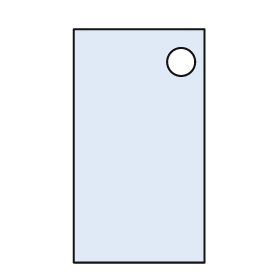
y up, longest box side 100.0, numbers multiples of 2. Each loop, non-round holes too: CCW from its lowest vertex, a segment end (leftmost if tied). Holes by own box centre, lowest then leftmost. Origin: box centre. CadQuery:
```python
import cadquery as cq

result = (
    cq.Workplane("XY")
    .moveTo(-28.0, -50.0)
    .lineTo(28.0, -50.0)
    .lineTo(28.0, 50.0)
    .lineTo(-28.0, 50.0)
    .close()
    .moveTo(18.0, 36.0)
    .circle(6.0)
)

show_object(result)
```